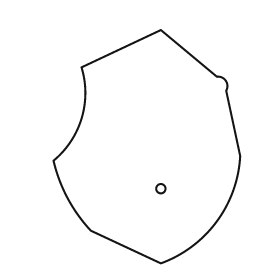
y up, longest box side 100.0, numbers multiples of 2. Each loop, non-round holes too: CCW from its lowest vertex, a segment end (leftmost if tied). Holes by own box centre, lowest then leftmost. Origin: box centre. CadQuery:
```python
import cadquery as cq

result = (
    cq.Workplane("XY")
    .moveTo(6.0, -50.0)
    .threePointArc((30.0, -32.0), (40.0, -4.0))
    .lineTo(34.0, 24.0)
    .threePointArc((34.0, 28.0), (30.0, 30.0))
    .lineTo(6.0, 50.0)
    .lineTo(-28.0, 34.0)
    .threePointArc((-28.0, 12.0), (-40.0, -6.0))
    .threePointArc((-34.0, -22.0), (-24.0, -36.0))
    .close()
    .moveTo(6.0, -18.0)
    .circle(2.0)
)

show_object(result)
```